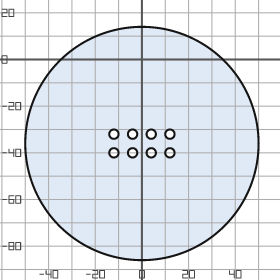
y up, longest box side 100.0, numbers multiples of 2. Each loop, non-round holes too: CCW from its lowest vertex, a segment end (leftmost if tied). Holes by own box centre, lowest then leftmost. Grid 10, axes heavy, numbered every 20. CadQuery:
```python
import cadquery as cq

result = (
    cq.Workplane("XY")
    .moveTo(0.0, -36.0)
    .circle(50.0)
    .moveTo(-12.0, -40.0)
    .circle(2.0)
    .moveTo(-4.0, -40.0)
    .circle(2.0)
    .moveTo(4.0, -40.0)
    .circle(2.0)
    .moveTo(12.0, -40.0)
    .circle(2.0)
    .moveTo(-12.0, -32.0)
    .circle(2.0)
    .moveTo(-4.0, -32.0)
    .circle(2.0)
    .moveTo(4.0, -32.0)
    .circle(2.0)
    .moveTo(12.0, -32.0)
    .circle(2.0)
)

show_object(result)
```